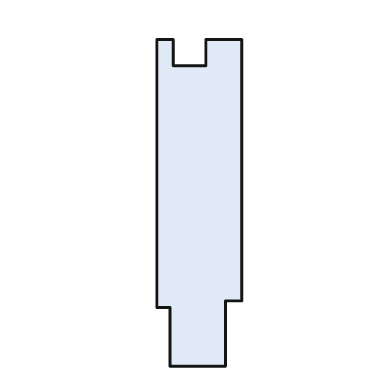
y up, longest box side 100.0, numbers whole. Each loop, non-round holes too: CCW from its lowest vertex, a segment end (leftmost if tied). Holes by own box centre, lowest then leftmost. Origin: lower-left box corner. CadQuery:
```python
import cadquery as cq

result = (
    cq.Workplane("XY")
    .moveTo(4.0, 0.0)
    .lineTo(21.0, 0.0)
    .lineTo(21.0, 20.0)
    .lineTo(26.0, 20.0)
    .lineTo(26.0, 100.0)
    .lineTo(15.0, 100.0)
    .lineTo(15.0, 92.0)
    .lineTo(5.0, 92.0)
    .lineTo(5.0, 100.0)
    .lineTo(0.0, 100.0)
    .lineTo(0.0, 18.0)
    .lineTo(4.0, 18.0)
    .close()
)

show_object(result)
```